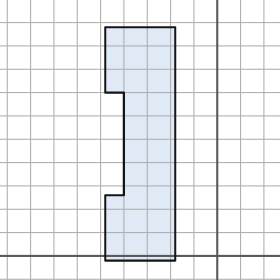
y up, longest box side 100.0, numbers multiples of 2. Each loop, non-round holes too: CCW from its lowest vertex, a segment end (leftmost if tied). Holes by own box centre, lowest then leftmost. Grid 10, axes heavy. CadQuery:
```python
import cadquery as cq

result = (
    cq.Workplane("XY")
    .moveTo(-48.0, -2.0)
    .lineTo(-18.0, -2.0)
    .lineTo(-18.0, 98.0)
    .lineTo(-48.0, 98.0)
    .lineTo(-48.0, 70.0)
    .lineTo(-40.0, 70.0)
    .lineTo(-40.0, 26.0)
    .lineTo(-48.0, 26.0)
    .close()
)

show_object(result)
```